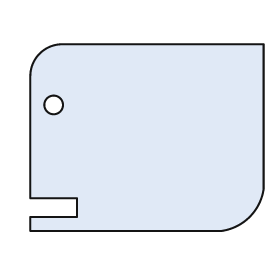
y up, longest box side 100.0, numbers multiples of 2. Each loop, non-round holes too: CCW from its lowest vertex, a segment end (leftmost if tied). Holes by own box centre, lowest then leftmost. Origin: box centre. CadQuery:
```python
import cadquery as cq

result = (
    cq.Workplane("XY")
    .moveTo(-50.0, -40.0)
    .lineTo(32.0, -40.0)
    .threePointArc((44.0, -34.0), (50.0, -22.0))
    .lineTo(50.0, 40.0)
    .lineTo(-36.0, 40.0)
    .threePointArc((-46.0, 36.0), (-50.0, 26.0))
    .lineTo(-50.0, -26.0)
    .lineTo(-30.0, -26.0)
    .lineTo(-30.0, -34.0)
    .lineTo(-50.0, -34.0)
    .close()
    .moveTo(-40.0, 14.0)
    .circle(4.0)
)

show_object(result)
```